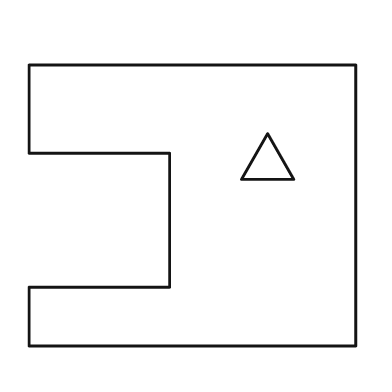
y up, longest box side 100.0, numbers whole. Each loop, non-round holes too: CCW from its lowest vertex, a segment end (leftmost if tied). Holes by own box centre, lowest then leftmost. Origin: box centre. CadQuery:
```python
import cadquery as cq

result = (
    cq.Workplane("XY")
    .moveTo(-50.0, -43.0)
    .lineTo(50.0, -43.0)
    .lineTo(50.0, 43.0)
    .lineTo(-50.0, 43.0)
    .lineTo(-50.0, 16.0)
    .lineTo(-7.0, 16.0)
    .lineTo(-7.0, -25.0)
    .lineTo(-50.0, -25.0)
    .close()
    .moveTo(15.0, 8.0)
    .lineTo(31.0, 8.0)
    .lineTo(23.0, 22.0)
    .close()
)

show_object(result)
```